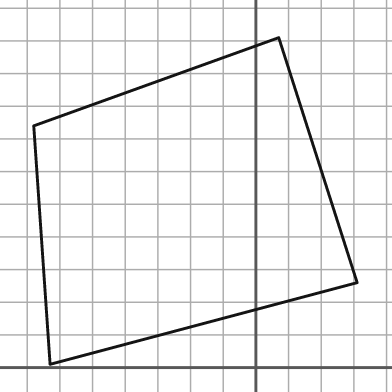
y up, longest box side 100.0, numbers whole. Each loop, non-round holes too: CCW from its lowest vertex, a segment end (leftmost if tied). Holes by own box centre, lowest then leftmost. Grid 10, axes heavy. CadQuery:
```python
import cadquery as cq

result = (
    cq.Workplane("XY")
    .moveTo(-63.0, 1.0)
    .lineTo(31.0, 26.0)
    .lineTo(7.0, 101.0)
    .lineTo(-68.0, 74.0)
    .close()
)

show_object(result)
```